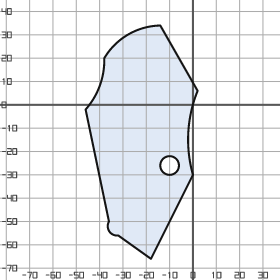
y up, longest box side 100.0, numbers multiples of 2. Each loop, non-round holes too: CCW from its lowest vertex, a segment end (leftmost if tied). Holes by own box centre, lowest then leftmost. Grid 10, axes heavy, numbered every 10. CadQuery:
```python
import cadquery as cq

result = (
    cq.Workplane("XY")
    .moveTo(-18.0, -66.0)
    .lineTo(0.0, -30.0)
    .threePointArc((-2.0, -12.0), (2.0, 6.0))
    .lineTo(-14.0, 34.0)
    .threePointArc((-28.0, 30.0), (-38.0, 20.0))
    .threePointArc((-40.0, 8.0), (-46.0, -2.0))
    .lineTo(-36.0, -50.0)
    .threePointArc((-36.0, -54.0), (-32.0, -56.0))
    .close()
    .moveTo(-10.0, -26.0)
    .circle(4.0)
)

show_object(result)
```